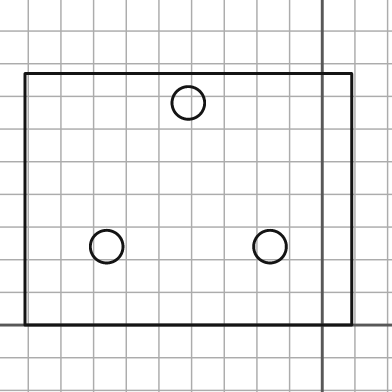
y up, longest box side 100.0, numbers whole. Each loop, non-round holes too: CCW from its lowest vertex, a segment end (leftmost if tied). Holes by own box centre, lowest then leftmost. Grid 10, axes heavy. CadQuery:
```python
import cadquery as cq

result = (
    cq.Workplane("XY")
    .moveTo(-91.0, 0.0)
    .lineTo(9.0, 0.0)
    .lineTo(9.0, 77.0)
    .lineTo(-91.0, 77.0)
    .close()
    .moveTo(-66.0, 24.0)
    .circle(5.0)
    .moveTo(-16.0, 24.0)
    .circle(5.0)
    .moveTo(-41.0, 68.0)
    .circle(5.0)
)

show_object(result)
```